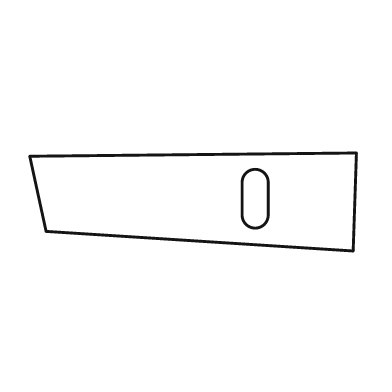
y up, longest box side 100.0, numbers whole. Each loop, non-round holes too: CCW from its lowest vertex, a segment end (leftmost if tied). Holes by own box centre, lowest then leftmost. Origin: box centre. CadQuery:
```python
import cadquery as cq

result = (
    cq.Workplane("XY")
    .moveTo(49.0, -15.0)
    .lineTo(50.0, 15.0)
    .lineTo(-50.0, 14.0)
    .lineTo(-45.0, -9.0)
    .close()
    .moveTo(15.0, -4.0)
    .threePointArc((19.0, -8.0), (23.0, -4.0))
    .lineTo(23.0, 6.0)
    .threePointArc((19.0, 10.0), (15.0, 6.0))
    .close()
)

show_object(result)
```